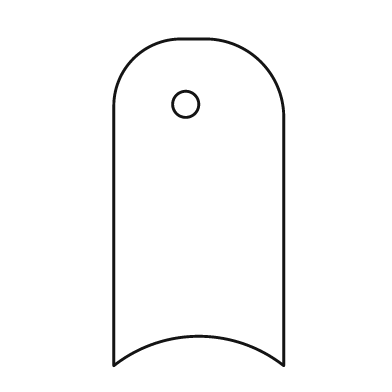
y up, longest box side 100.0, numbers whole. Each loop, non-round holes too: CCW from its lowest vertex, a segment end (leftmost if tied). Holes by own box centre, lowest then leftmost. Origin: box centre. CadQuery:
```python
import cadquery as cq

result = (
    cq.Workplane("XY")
    .moveTo(-26.0, -50.0)
    .threePointArc((0.0, -41.0), (26.0, -50.0))
    .lineTo(26.0, 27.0)
    .threePointArc((19.0, 43.0), (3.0, 50.0))
    .lineTo(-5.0, 50.0)
    .threePointArc((-20.0, 44.0), (-26.0, 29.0))
    .close()
    .moveTo(-4.0, 30.0)
    .circle(4.0)
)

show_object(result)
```